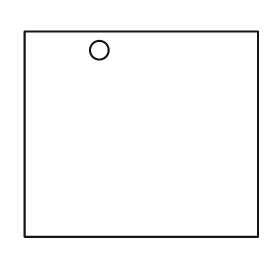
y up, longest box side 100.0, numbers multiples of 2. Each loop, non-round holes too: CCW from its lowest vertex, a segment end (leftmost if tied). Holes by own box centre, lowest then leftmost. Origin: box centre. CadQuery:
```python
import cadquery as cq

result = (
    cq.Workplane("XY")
    .moveTo(-50.0, -44.0)
    .lineTo(50.0, -44.0)
    .lineTo(50.0, 44.0)
    .lineTo(-50.0, 44.0)
    .close()
    .moveTo(-18.0, 36.0)
    .circle(4.0)
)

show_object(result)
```